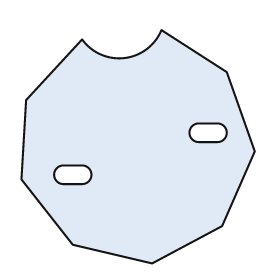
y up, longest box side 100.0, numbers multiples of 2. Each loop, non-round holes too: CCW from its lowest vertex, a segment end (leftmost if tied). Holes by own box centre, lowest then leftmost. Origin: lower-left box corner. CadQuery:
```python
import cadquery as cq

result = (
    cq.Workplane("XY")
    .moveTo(56.0, 0.0)
    .lineTo(86.0, 16.0)
    .lineTo(100.0, 48.0)
    .lineTo(88.0, 82.0)
    .lineTo(60.0, 100.0)
    .threePointArc((44.0, 88.0), (26.0, 96.0))
    .lineTo(2.0, 70.0)
    .lineTo(0.0, 36.0)
    .lineTo(22.0, 8.0)
    .close()
    .moveTo(18.0, 34.0)
    .lineTo(26.0, 34.0)
    .threePointArc((30.0, 38.0), (26.0, 42.0))
    .lineTo(18.0, 42.0)
    .threePointArc((14.0, 38.0), (18.0, 34.0))
    .close()
    .moveTo(76.0, 52.0)
    .lineTo(84.0, 52.0)
    .threePointArc((88.0, 56.0), (84.0, 60.0))
    .lineTo(76.0, 60.0)
    .threePointArc((72.0, 56.0), (76.0, 52.0))
    .close()
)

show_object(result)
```